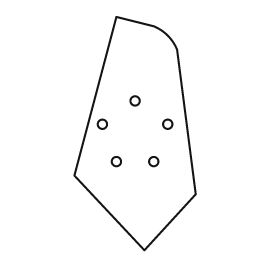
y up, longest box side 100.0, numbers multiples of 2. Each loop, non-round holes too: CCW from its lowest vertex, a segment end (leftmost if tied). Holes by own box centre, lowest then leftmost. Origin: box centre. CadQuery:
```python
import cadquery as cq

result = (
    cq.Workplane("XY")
    .moveTo(4.0, -50.0)
    .lineTo(26.0, -26.0)
    .lineTo(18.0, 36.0)
    .threePointArc((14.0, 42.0), (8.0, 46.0))
    .lineTo(-8.0, 50.0)
    .lineTo(-26.0, -18.0)
    .close()
    .moveTo(-8.0, -12.0)
    .circle(2.0)
    .moveTo(8.0, -12.0)
    .circle(2.0)
    .moveTo(-14.0, 4.0)
    .circle(2.0)
    .moveTo(14.0, 4.0)
    .circle(2.0)
    .moveTo(0.0, 14.0)
    .circle(2.0)
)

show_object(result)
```